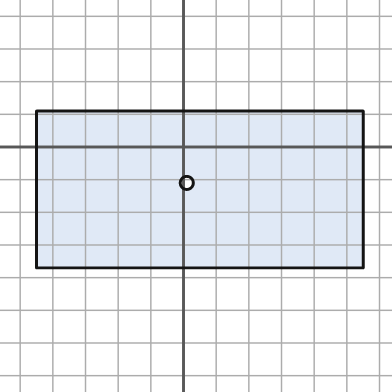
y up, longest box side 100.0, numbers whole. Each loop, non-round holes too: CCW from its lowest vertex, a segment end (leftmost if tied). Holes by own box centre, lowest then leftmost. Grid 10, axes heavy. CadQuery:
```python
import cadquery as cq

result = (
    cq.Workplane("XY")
    .moveTo(-45.0, -37.0)
    .lineTo(55.0, -37.0)
    .lineTo(55.0, 11.0)
    .lineTo(-45.0, 11.0)
    .close()
    .moveTo(1.0, -11.0)
    .circle(2.0)
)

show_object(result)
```